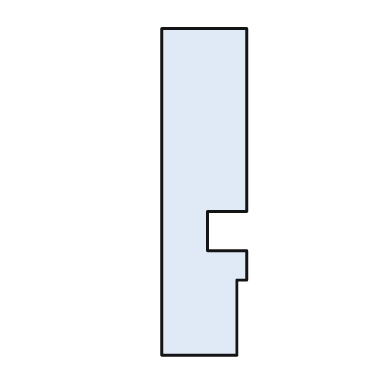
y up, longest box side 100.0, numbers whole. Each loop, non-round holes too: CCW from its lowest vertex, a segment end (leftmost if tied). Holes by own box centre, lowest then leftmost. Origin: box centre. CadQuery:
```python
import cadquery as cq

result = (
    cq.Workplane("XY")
    .moveTo(-13.0, -50.0)
    .lineTo(10.0, -50.0)
    .lineTo(10.0, -27.0)
    .lineTo(13.0, -27.0)
    .lineTo(13.0, -18.0)
    .lineTo(1.0, -18.0)
    .lineTo(1.0, -6.0)
    .lineTo(13.0, -6.0)
    .lineTo(13.0, 50.0)
    .lineTo(-13.0, 50.0)
    .close()
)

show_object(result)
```